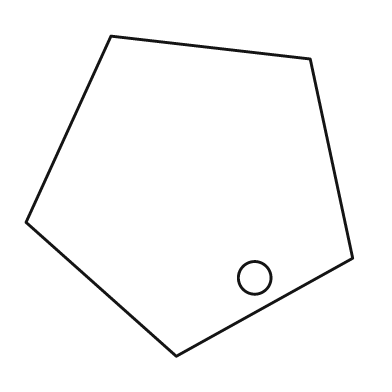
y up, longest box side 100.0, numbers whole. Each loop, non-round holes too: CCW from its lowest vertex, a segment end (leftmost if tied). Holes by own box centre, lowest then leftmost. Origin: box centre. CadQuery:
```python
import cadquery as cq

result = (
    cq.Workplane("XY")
    .moveTo(-4.0, -49.0)
    .lineTo(50.0, -19.0)
    .lineTo(37.0, 42.0)
    .lineTo(-24.0, 49.0)
    .lineTo(-50.0, -8.0)
    .close()
    .moveTo(20.0, -25.0)
    .circle(5.0)
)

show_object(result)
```